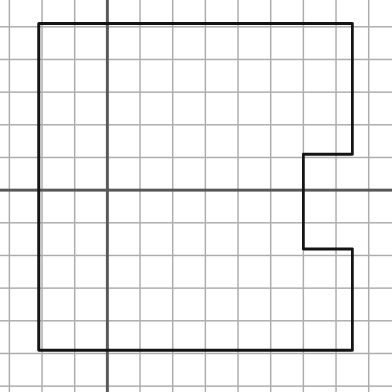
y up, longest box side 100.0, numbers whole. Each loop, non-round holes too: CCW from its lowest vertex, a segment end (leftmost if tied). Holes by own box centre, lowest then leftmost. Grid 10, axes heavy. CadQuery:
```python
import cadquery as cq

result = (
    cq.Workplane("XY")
    .moveTo(-21.0, -49.0)
    .lineTo(75.0, -49.0)
    .lineTo(75.0, -18.0)
    .lineTo(60.0, -18.0)
    .lineTo(60.0, 11.0)
    .lineTo(75.0, 11.0)
    .lineTo(75.0, 51.0)
    .lineTo(-21.0, 51.0)
    .close()
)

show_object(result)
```